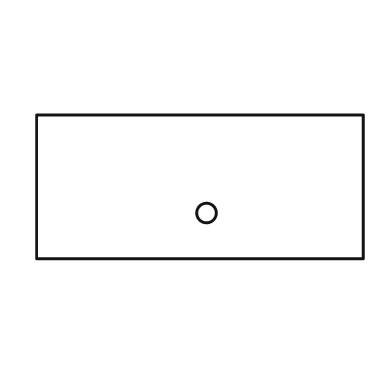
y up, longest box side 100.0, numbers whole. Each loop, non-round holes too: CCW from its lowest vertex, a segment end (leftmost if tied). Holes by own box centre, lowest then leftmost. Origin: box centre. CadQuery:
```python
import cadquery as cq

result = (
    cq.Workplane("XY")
    .moveTo(-50.0, -22.0)
    .lineTo(50.0, -22.0)
    .lineTo(50.0, 22.0)
    .lineTo(-50.0, 22.0)
    .close()
    .moveTo(2.0, -8.0)
    .circle(3.0)
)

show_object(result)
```